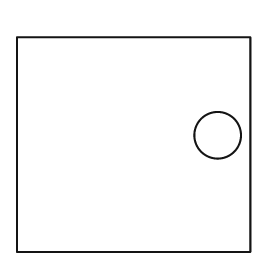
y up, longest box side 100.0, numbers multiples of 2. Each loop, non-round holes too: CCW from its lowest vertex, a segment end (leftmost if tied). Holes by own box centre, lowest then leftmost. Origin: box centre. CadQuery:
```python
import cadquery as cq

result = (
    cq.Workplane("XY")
    .moveTo(-50.0, -46.0)
    .lineTo(50.0, -46.0)
    .lineTo(50.0, 46.0)
    .lineTo(-50.0, 46.0)
    .close()
    .moveTo(36.0, 4.0)
    .circle(10.0)
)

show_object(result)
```